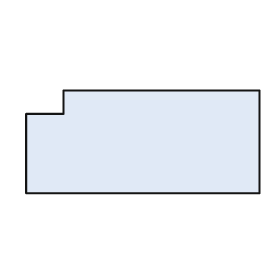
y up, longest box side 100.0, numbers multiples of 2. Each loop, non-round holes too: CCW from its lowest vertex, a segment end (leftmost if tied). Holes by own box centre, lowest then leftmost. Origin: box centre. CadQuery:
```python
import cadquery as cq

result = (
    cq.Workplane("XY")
    .moveTo(-50.0, -22.0)
    .lineTo(50.0, -22.0)
    .lineTo(50.0, 22.0)
    .lineTo(-34.0, 22.0)
    .lineTo(-34.0, 12.0)
    .lineTo(-50.0, 12.0)
    .close()
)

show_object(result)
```